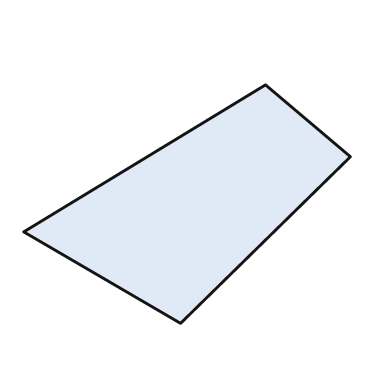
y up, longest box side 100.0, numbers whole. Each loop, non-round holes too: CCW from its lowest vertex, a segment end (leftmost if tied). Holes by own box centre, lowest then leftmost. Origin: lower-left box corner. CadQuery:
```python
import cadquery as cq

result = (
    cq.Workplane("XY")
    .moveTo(48.0, 0.0)
    .lineTo(100.0, 51.0)
    .lineTo(74.0, 73.0)
    .lineTo(0.0, 28.0)
    .close()
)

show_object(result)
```